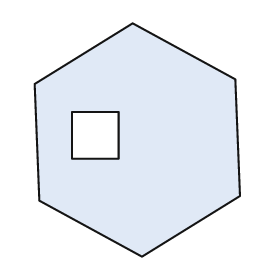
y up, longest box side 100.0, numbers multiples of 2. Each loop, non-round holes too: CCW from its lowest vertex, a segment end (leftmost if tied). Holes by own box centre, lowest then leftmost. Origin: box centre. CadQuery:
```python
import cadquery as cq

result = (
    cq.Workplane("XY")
    .moveTo(2.0, -50.0)
    .lineTo(44.0, -24.0)
    .lineTo(42.0, 26.0)
    .lineTo(-2.0, 50.0)
    .lineTo(-44.0, 24.0)
    .lineTo(-42.0, -26.0)
    .close()
    .moveTo(-28.0, -8.0)
    .lineTo(-8.0, -8.0)
    .lineTo(-8.0, 12.0)
    .lineTo(-28.0, 12.0)
    .close()
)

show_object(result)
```